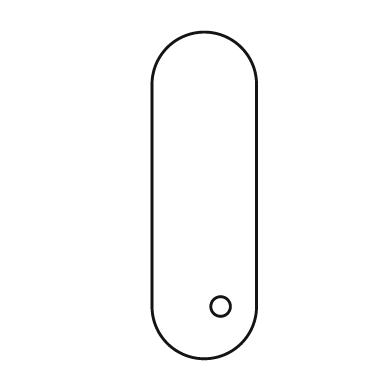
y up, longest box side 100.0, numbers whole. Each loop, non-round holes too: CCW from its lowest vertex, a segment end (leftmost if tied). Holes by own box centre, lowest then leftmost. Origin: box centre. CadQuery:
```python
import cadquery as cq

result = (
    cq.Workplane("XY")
    .moveTo(-16.0, -34.0)
    .threePointArc((0.0, -50.0), (16.0, -34.0))
    .lineTo(16.0, 34.0)
    .threePointArc((0.0, 50.0), (-16.0, 34.0))
    .close()
    .moveTo(5.0, -34.0)
    .circle(3.0)
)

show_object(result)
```